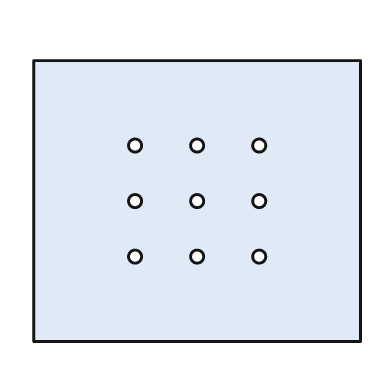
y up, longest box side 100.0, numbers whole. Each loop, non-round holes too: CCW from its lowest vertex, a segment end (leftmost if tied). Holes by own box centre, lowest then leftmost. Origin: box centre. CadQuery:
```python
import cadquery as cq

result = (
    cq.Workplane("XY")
    .moveTo(-50.0, -43.0)
    .lineTo(50.0, -43.0)
    .lineTo(50.0, 43.0)
    .lineTo(-50.0, 43.0)
    .close()
    .moveTo(-19.0, -17.0)
    .circle(2.0)
    .moveTo(0.0, -17.0)
    .circle(2.0)
    .moveTo(19.0, -17.0)
    .circle(2.0)
    .moveTo(-19.0, 0.0)
    .circle(2.0)
    .moveTo(0.0, 0.0)
    .circle(2.0)
    .moveTo(19.0, 0.0)
    .circle(2.0)
    .moveTo(-19.0, 17.0)
    .circle(2.0)
    .moveTo(0.0, 17.0)
    .circle(2.0)
    .moveTo(19.0, 17.0)
    .circle(2.0)
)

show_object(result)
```